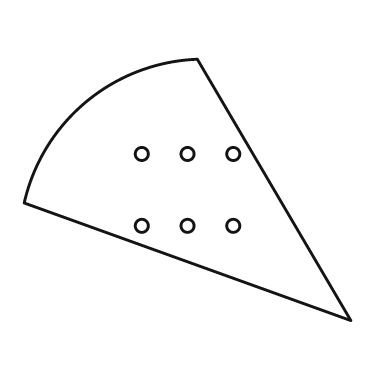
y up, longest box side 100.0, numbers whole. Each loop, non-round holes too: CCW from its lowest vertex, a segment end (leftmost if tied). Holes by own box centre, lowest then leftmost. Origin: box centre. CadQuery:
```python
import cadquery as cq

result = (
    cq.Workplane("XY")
    .moveTo(50.0, -40.0)
    .lineTo(3.0, 40.0)
    .threePointArc((-31.0, 27.0), (-50.0, -4.0))
    .close()
    .moveTo(-14.0, -11.0)
    .circle(2.0)
    .moveTo(0.0, -11.0)
    .circle(2.0)
    .moveTo(14.0, -11.0)
    .circle(2.0)
    .moveTo(-14.0, 11.0)
    .circle(2.0)
    .moveTo(0.0, 11.0)
    .circle(2.0)
    .moveTo(14.0, 11.0)
    .circle(2.0)
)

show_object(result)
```